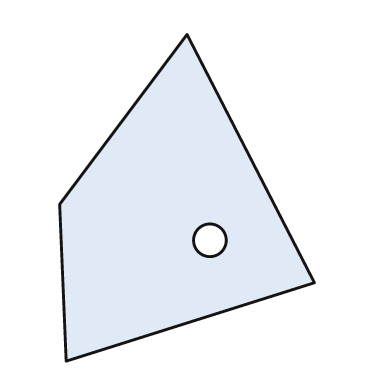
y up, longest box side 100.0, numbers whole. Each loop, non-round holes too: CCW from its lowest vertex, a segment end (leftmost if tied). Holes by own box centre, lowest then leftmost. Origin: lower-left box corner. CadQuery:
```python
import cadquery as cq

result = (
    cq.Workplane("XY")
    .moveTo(2.0, 0.0)
    .lineTo(78.0, 24.0)
    .lineTo(39.0, 100.0)
    .lineTo(0.0, 48.0)
    .close()
    .moveTo(46.0, 37.0)
    .circle(5.0)
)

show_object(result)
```